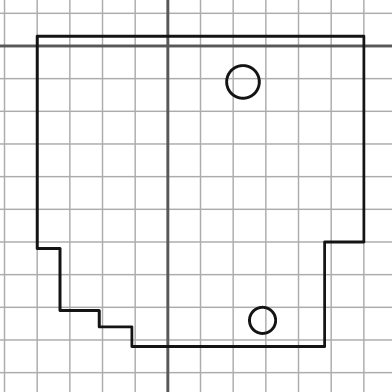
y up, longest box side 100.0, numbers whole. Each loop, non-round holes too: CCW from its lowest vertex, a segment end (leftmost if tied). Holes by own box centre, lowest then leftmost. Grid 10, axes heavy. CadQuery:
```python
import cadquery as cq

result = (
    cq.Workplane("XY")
    .moveTo(-11.0, -92.0)
    .lineTo(48.0, -92.0)
    .lineTo(48.0, -60.0)
    .lineTo(60.0, -60.0)
    .lineTo(60.0, 3.0)
    .lineTo(-40.0, 3.0)
    .lineTo(-40.0, -62.0)
    .lineTo(-33.0, -62.0)
    .lineTo(-33.0, -81.0)
    .lineTo(-21.0, -81.0)
    .lineTo(-21.0, -86.0)
    .lineTo(-11.0, -86.0)
    .close()
    .moveTo(29.0, -84.0)
    .circle(4.0)
    .moveTo(23.0, -11.0)
    .circle(5.0)
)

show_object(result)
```